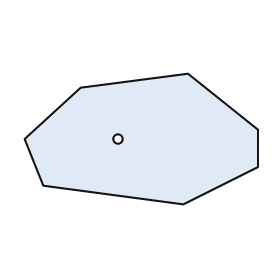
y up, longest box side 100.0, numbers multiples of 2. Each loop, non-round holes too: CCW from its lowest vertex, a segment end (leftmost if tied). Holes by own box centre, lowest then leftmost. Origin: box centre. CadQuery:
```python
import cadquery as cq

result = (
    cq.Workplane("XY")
    .moveTo(18.0, -28.0)
    .lineTo(50.0, -12.0)
    .lineTo(50.0, 4.0)
    .lineTo(20.0, 28.0)
    .lineTo(-26.0, 22.0)
    .lineTo(-50.0, 0.0)
    .lineTo(-42.0, -20.0)
    .close()
    .moveTo(-10.0, 0.0)
    .circle(2.0)
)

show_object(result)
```